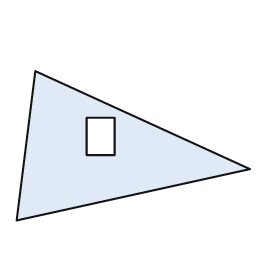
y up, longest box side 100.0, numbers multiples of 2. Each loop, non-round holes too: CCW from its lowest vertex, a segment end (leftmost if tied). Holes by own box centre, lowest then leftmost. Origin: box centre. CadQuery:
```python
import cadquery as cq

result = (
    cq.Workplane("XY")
    .moveTo(-50.0, -32.0)
    .lineTo(50.0, -10.0)
    .lineTo(-42.0, 32.0)
    .close()
    .moveTo(-20.0, -4.0)
    .lineTo(-8.0, -4.0)
    .lineTo(-8.0, 12.0)
    .lineTo(-20.0, 12.0)
    .close()
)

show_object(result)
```